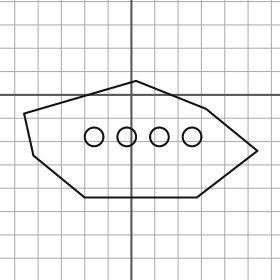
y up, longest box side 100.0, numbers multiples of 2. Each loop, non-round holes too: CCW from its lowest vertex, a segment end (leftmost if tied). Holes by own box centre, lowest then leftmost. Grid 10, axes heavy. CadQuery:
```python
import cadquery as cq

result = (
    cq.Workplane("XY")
    .moveTo(-20.0, -44.0)
    .lineTo(28.0, -44.0)
    .lineTo(54.0, -24.0)
    .lineTo(32.0, -6.0)
    .lineTo(2.0, 6.0)
    .lineTo(-46.0, -8.0)
    .lineTo(-42.0, -26.0)
    .close()
    .moveTo(-16.0, -18.0)
    .circle(4.0)
    .moveTo(-2.0, -18.0)
    .circle(4.0)
    .moveTo(12.0, -18.0)
    .circle(4.0)
    .moveTo(26.0, -18.0)
    .circle(4.0)
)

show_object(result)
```